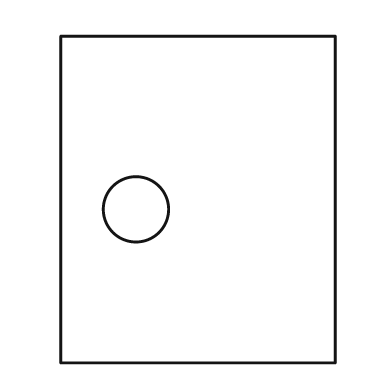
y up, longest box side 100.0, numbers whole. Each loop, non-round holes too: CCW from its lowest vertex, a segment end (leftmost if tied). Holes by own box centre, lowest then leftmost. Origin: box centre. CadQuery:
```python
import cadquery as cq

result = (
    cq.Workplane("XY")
    .moveTo(-42.0, -50.0)
    .lineTo(42.0, -50.0)
    .lineTo(42.0, 50.0)
    .lineTo(-42.0, 50.0)
    .close()
    .moveTo(-19.0, -3.0)
    .circle(10.0)
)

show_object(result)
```